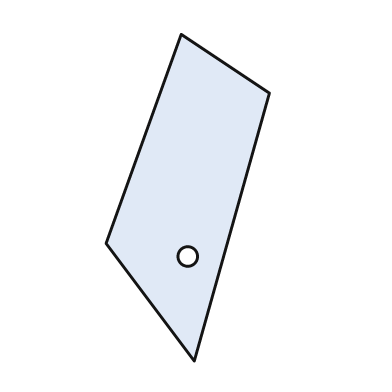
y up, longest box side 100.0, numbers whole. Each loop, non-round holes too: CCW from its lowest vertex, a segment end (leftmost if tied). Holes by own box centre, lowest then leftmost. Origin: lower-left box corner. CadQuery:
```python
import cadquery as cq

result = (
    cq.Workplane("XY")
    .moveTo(27.0, 0.0)
    .lineTo(50.0, 82.0)
    .lineTo(23.0, 100.0)
    .lineTo(0.0, 36.0)
    .close()
    .moveTo(25.0, 32.0)
    .circle(3.0)
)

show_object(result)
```